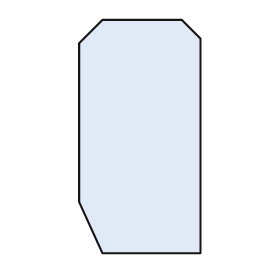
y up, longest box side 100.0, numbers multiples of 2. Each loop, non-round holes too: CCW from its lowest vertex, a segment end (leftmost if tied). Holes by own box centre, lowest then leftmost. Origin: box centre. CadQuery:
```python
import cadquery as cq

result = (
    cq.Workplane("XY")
    .moveTo(-16.0, -50.0)
    .lineTo(26.0, -50.0)
    .lineTo(26.0, 42.0)
    .lineTo(18.0, 50.0)
    .lineTo(-16.0, 50.0)
    .lineTo(-26.0, 40.0)
    .lineTo(-26.0, -28.0)
    .close()
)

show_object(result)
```